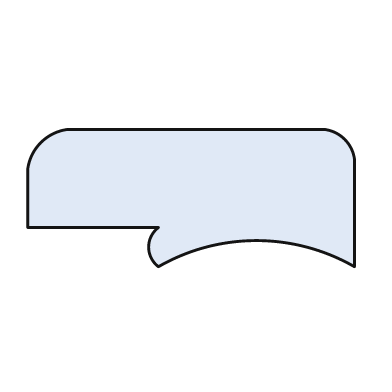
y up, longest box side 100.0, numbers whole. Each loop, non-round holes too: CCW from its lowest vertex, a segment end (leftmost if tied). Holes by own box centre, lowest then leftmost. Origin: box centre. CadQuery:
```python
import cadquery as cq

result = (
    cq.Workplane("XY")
    .moveTo(-10.0, -21.0)
    .threePointArc((20.0, -13.0), (50.0, -21.0))
    .lineTo(50.0, 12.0)
    .threePointArc((47.0, 18.0), (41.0, 21.0))
    .lineTo(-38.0, 21.0)
    .threePointArc((-46.0, 17.0), (-50.0, 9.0))
    .lineTo(-50.0, -9.0)
    .lineTo(-10.0, -9.0)
    .threePointArc((-13.0, -15.0), (-10.0, -21.0))
    .close()
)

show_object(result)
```